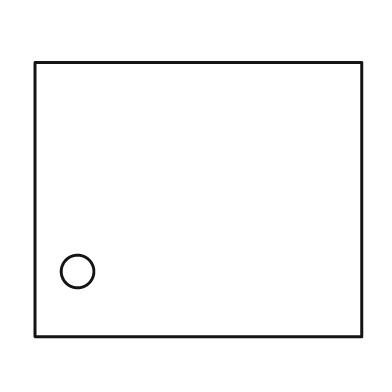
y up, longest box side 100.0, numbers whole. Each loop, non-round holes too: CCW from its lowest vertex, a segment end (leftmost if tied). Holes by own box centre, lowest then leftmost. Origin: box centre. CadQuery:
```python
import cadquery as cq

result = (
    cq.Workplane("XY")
    .moveTo(-50.0, -42.0)
    .lineTo(50.0, -42.0)
    .lineTo(50.0, 42.0)
    .lineTo(-50.0, 42.0)
    .close()
    .moveTo(-37.0, -22.0)
    .circle(5.0)
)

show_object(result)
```